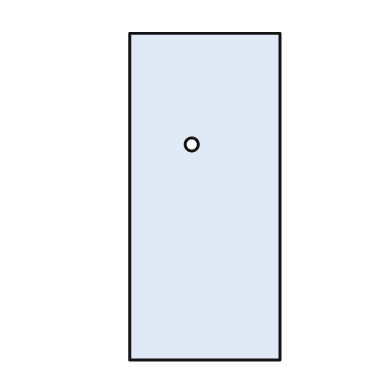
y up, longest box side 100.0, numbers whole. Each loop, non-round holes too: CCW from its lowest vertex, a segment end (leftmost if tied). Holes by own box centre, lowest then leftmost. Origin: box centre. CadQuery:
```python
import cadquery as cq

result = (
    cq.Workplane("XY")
    .moveTo(-23.0, -50.0)
    .lineTo(23.0, -50.0)
    .lineTo(23.0, 50.0)
    .lineTo(-23.0, 50.0)
    .close()
    .moveTo(-4.0, 16.0)
    .circle(2.0)
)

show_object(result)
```